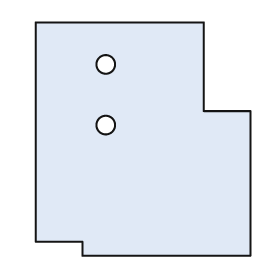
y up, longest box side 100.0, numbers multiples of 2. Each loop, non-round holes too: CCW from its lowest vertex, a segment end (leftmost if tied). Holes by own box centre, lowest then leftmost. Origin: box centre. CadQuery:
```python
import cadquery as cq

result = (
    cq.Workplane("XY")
    .moveTo(-26.0, -50.0)
    .lineTo(46.0, -50.0)
    .lineTo(46.0, 12.0)
    .lineTo(26.0, 12.0)
    .lineTo(26.0, 50.0)
    .lineTo(-46.0, 50.0)
    .lineTo(-46.0, -44.0)
    .lineTo(-26.0, -44.0)
    .close()
    .moveTo(-16.0, 6.0)
    .circle(4.0)
    .moveTo(-16.0, 32.0)
    .circle(4.0)
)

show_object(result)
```